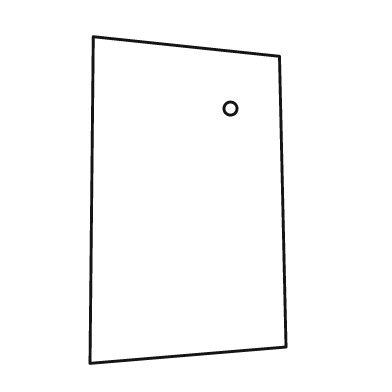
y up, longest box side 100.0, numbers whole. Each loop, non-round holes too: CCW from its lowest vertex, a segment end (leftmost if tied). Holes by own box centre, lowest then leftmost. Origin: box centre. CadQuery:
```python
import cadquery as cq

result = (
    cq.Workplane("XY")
    .moveTo(-30.0, -50.0)
    .lineTo(30.0, -45.0)
    .lineTo(28.0, 44.0)
    .lineTo(-29.0, 50.0)
    .close()
    .moveTo(13.0, 28.0)
    .circle(2.0)
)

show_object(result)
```